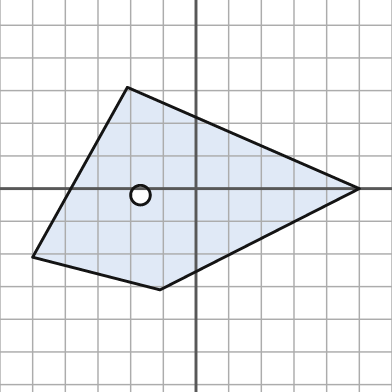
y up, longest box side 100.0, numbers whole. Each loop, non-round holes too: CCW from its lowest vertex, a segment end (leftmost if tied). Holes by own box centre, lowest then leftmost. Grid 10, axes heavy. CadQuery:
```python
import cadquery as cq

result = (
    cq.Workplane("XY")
    .moveTo(-11.0, -31.0)
    .lineTo(50.0, 0.0)
    .lineTo(-21.0, 31.0)
    .lineTo(-50.0, -21.0)
    .close()
    .moveTo(-17.0, -2.0)
    .circle(3.0)
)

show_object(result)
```